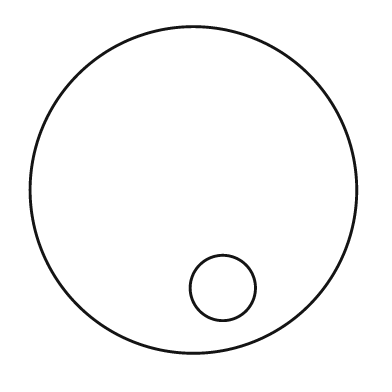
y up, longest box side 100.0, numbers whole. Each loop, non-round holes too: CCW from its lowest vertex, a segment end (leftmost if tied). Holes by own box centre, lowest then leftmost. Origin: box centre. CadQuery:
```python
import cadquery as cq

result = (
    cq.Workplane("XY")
    .moveTo(0.0, 0.0)
    .circle(50.0)
    .moveTo(9.0, -30.0)
    .circle(10.0)
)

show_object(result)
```